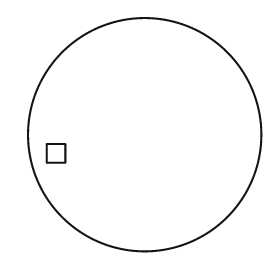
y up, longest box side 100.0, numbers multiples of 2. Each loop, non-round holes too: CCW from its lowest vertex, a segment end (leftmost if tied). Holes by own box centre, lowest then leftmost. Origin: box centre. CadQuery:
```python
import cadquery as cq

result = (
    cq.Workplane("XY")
    .moveTo(0.0, 0.0)
    .circle(50.0)
    .moveTo(-42.0, -12.0)
    .lineTo(-34.0, -12.0)
    .lineTo(-34.0, -4.0)
    .lineTo(-42.0, -4.0)
    .close()
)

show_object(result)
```